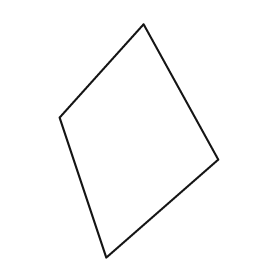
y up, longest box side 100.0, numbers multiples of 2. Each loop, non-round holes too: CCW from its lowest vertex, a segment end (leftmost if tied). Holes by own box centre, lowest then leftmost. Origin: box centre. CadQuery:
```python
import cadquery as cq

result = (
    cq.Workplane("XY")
    .moveTo(-14.0, -50.0)
    .lineTo(34.0, -8.0)
    .lineTo(2.0, 50.0)
    .lineTo(-34.0, 10.0)
    .close()
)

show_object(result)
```